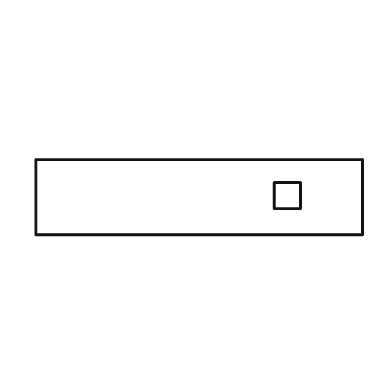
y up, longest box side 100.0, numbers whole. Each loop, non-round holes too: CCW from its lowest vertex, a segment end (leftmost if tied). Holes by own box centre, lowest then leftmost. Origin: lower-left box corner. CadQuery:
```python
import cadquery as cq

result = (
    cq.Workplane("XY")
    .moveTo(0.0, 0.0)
    .lineTo(100.0, 0.0)
    .lineTo(100.0, 23.0)
    .lineTo(0.0, 23.0)
    .close()
    .moveTo(73.0, 8.0)
    .lineTo(81.0, 8.0)
    .lineTo(81.0, 16.0)
    .lineTo(73.0, 16.0)
    .close()
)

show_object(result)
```